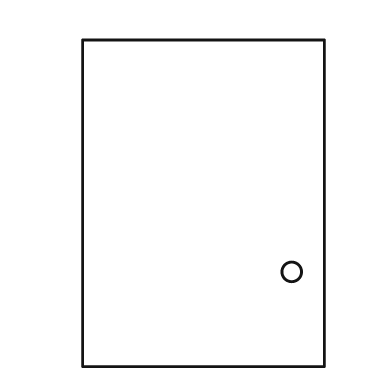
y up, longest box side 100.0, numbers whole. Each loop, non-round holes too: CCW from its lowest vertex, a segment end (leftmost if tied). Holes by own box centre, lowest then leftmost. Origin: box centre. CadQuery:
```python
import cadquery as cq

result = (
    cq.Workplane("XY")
    .moveTo(-37.0, -50.0)
    .lineTo(37.0, -50.0)
    .lineTo(37.0, 50.0)
    .lineTo(-37.0, 50.0)
    .close()
    .moveTo(27.0, -21.0)
    .circle(3.0)
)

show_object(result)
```